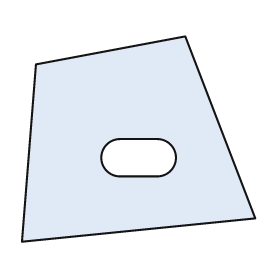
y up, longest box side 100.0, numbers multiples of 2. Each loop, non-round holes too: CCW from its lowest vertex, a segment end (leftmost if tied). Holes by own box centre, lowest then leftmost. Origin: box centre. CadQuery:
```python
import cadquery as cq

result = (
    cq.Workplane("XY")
    .moveTo(-50.0, -44.0)
    .lineTo(50.0, -34.0)
    .lineTo(20.0, 44.0)
    .lineTo(-44.0, 32.0)
    .close()
    .moveTo(-8.0, -16.0)
    .lineTo(8.0, -16.0)
    .threePointArc((16.0, -8.0), (8.0, 0.0))
    .lineTo(-8.0, 0.0)
    .threePointArc((-16.0, -8.0), (-8.0, -16.0))
    .close()
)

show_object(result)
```